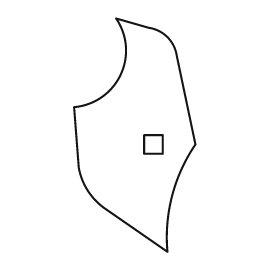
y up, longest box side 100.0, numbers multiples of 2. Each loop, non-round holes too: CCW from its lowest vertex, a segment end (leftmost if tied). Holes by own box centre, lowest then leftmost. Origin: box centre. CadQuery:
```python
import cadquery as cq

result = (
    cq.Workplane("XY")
    .moveTo(14.0, -50.0)
    .threePointArc((16.0, -26.0), (26.0, -4.0))
    .lineTo(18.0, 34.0)
    .threePointArc((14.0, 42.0), (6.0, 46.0))
    .lineTo(-8.0, 50.0)
    .threePointArc((-6.0, 26.0), (-26.0, 12.0))
    .lineTo(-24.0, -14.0)
    .threePointArc((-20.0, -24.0), (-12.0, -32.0))
    .close()
    .moveTo(4.0, -8.0)
    .lineTo(12.0, -8.0)
    .lineTo(12.0, 0.0)
    .lineTo(4.0, 0.0)
    .close()
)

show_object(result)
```